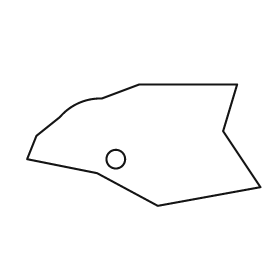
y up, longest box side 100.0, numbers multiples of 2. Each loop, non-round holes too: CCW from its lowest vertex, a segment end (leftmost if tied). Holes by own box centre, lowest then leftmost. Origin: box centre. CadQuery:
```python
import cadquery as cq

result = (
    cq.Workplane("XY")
    .moveTo(6.0, -26.0)
    .lineTo(50.0, -18.0)
    .lineTo(34.0, 6.0)
    .lineTo(40.0, 26.0)
    .lineTo(-2.0, 26.0)
    .lineTo(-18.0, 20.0)
    .threePointArc((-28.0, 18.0), (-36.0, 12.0))
    .lineTo(-46.0, 4.0)
    .lineTo(-50.0, -6.0)
    .lineTo(-20.0, -12.0)
    .close()
    .moveTo(-12.0, -6.0)
    .circle(4.0)
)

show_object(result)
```